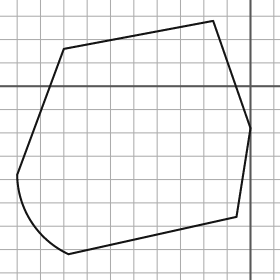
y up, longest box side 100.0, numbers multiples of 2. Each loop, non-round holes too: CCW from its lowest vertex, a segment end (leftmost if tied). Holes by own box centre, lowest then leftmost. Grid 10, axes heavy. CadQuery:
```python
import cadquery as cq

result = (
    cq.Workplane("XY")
    .moveTo(-78.0, -72.0)
    .lineTo(-6.0, -56.0)
    .lineTo(0.0, -18.0)
    .lineTo(-16.0, 28.0)
    .lineTo(-80.0, 16.0)
    .lineTo(-100.0, -38.0)
    .threePointArc((-94.0, -58.0), (-78.0, -72.0))
    .close()
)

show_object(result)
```